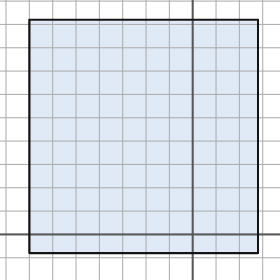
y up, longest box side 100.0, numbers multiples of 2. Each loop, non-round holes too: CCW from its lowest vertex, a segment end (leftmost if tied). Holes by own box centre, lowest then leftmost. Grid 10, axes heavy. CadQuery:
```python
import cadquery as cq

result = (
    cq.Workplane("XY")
    .moveTo(-70.0, -8.0)
    .lineTo(28.0, -8.0)
    .lineTo(28.0, 92.0)
    .lineTo(-70.0, 92.0)
    .close()
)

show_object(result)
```